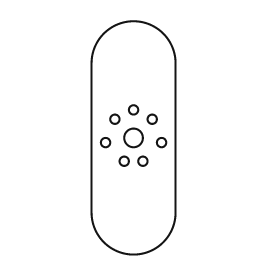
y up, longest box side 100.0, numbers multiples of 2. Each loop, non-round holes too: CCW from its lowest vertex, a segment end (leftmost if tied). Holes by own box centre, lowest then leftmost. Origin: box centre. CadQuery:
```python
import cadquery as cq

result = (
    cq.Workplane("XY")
    .moveTo(-18.0, -32.0)
    .threePointArc((0.0, -50.0), (18.0, -32.0))
    .lineTo(18.0, 32.0)
    .threePointArc((0.0, 50.0), (-18.0, 32.0))
    .close()
    .moveTo(-4.0, -10.0)
    .circle(2.0)
    .moveTo(4.0, -10.0)
    .circle(2.0)
    .moveTo(-12.0, -2.0)
    .circle(2.0)
    .moveTo(12.0, -2.0)
    .circle(2.0)
    .moveTo(0.0, 0.0)
    .circle(4.0)
    .moveTo(-8.0, 8.0)
    .circle(2.0)
    .moveTo(8.0, 8.0)
    .circle(2.0)
    .moveTo(0.0, 12.0)
    .circle(2.0)
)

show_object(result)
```